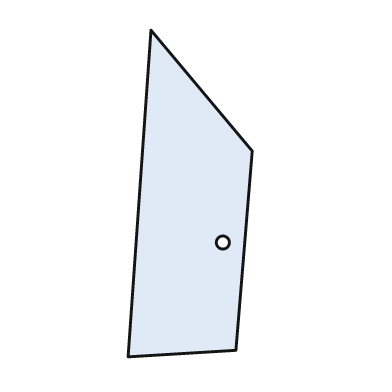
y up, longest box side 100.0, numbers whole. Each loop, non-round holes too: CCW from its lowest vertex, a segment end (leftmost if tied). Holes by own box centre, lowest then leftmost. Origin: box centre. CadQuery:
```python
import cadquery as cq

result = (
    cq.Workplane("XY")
    .moveTo(-19.0, -50.0)
    .lineTo(14.0, -48.0)
    .lineTo(19.0, 13.0)
    .lineTo(-12.0, 50.0)
    .close()
    .moveTo(10.0, -15.0)
    .circle(2.0)
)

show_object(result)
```